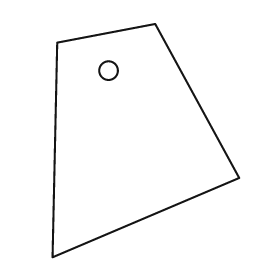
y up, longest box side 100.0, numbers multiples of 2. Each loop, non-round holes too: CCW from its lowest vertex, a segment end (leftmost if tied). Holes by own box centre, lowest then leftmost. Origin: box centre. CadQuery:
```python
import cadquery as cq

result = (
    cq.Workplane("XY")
    .moveTo(-40.0, -50.0)
    .lineTo(40.0, -16.0)
    .lineTo(4.0, 50.0)
    .lineTo(-38.0, 42.0)
    .close()
    .moveTo(-16.0, 30.0)
    .circle(4.0)
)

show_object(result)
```